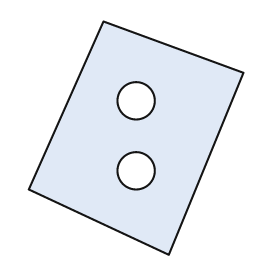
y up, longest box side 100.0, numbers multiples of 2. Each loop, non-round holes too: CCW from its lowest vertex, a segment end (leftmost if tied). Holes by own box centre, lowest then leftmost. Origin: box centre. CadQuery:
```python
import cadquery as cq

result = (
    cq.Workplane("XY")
    .moveTo(14.0, -50.0)
    .lineTo(46.0, 28.0)
    .lineTo(-14.0, 50.0)
    .lineTo(-46.0, -22.0)
    .close()
    .moveTo(0.0, -14.0)
    .circle(8.0)
    .moveTo(0.0, 16.0)
    .circle(8.0)
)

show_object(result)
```